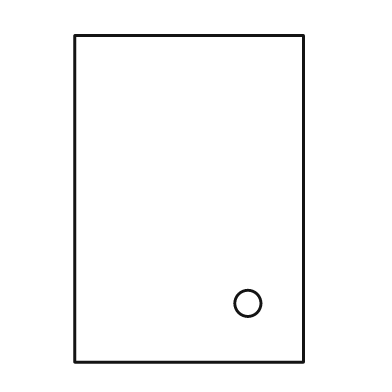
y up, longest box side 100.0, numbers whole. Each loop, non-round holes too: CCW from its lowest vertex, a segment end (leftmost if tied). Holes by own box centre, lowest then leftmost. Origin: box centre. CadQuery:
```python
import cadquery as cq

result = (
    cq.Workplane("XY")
    .moveTo(-35.0, -50.0)
    .lineTo(35.0, -50.0)
    .lineTo(35.0, 50.0)
    .lineTo(-35.0, 50.0)
    .close()
    .moveTo(18.0, -32.0)
    .circle(4.0)
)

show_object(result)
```